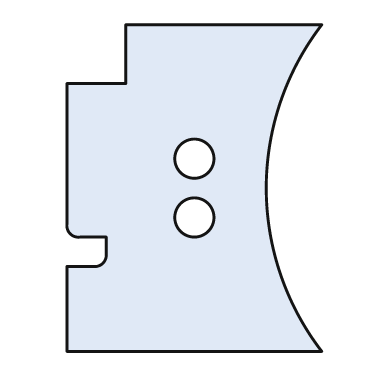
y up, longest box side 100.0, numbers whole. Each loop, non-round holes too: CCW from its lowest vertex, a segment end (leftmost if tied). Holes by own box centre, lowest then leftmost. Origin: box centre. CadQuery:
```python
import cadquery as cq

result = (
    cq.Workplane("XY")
    .moveTo(-39.0, -50.0)
    .lineTo(39.0, -50.0)
    .threePointArc((22.0, 0.0), (39.0, 50.0))
    .lineTo(-21.0, 50.0)
    .lineTo(-21.0, 32.0)
    .lineTo(-39.0, 32.0)
    .lineTo(-39.0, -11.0)
    .threePointArc((-38.0, -14.0), (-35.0, -15.0))
    .lineTo(-27.0, -15.0)
    .lineTo(-27.0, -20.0)
    .threePointArc((-28.0, -23.0), (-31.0, -24.0))
    .lineTo(-39.0, -24.0)
    .close()
    .moveTo(0.0, -9.0)
    .circle(6.0)
    .moveTo(0.0, 9.0)
    .circle(6.0)
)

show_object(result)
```